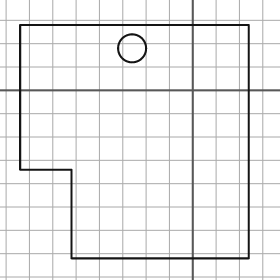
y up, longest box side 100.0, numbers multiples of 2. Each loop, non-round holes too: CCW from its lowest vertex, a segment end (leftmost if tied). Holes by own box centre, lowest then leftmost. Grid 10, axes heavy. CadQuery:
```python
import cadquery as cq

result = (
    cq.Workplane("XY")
    .moveTo(-52.0, -72.0)
    .lineTo(24.0, -72.0)
    .lineTo(24.0, 28.0)
    .lineTo(-74.0, 28.0)
    .lineTo(-74.0, -34.0)
    .lineTo(-52.0, -34.0)
    .close()
    .moveTo(-26.0, 18.0)
    .circle(6.0)
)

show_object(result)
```